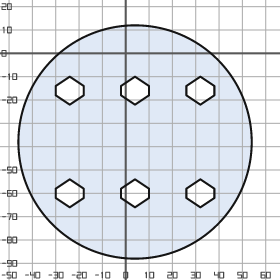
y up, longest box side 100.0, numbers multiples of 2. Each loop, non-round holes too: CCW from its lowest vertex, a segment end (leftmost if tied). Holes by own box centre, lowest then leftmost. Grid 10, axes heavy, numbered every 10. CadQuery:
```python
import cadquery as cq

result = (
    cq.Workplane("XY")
    .moveTo(4.0, -38.0)
    .circle(50.0)
    .moveTo(-24.0, -66.0)
    .lineTo(-18.0, -62.0)
    .lineTo(-18.0, -58.0)
    .lineTo(-24.0, -54.0)
    .lineTo(-30.0, -58.0)
    .lineTo(-30.0, -62.0)
    .close()
    .moveTo(4.0, -66.0)
    .lineTo(10.0, -62.0)
    .lineTo(10.0, -58.0)
    .lineTo(4.0, -54.0)
    .lineTo(-2.0, -58.0)
    .lineTo(-2.0, -62.0)
    .close()
    .moveTo(32.0, -66.0)
    .lineTo(38.0, -62.0)
    .lineTo(38.0, -58.0)
    .lineTo(32.0, -54.0)
    .lineTo(26.0, -58.0)
    .lineTo(26.0, -62.0)
    .close()
    .moveTo(-24.0, -22.0)
    .lineTo(-18.0, -18.0)
    .lineTo(-18.0, -14.0)
    .lineTo(-24.0, -10.0)
    .lineTo(-30.0, -14.0)
    .lineTo(-30.0, -18.0)
    .close()
    .moveTo(4.0, -22.0)
    .lineTo(10.0, -18.0)
    .lineTo(10.0, -14.0)
    .lineTo(4.0, -10.0)
    .lineTo(-2.0, -14.0)
    .lineTo(-2.0, -18.0)
    .close()
    .moveTo(32.0, -22.0)
    .lineTo(38.0, -18.0)
    .lineTo(38.0, -14.0)
    .lineTo(32.0, -10.0)
    .lineTo(26.0, -14.0)
    .lineTo(26.0, -18.0)
    .close()
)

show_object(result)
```